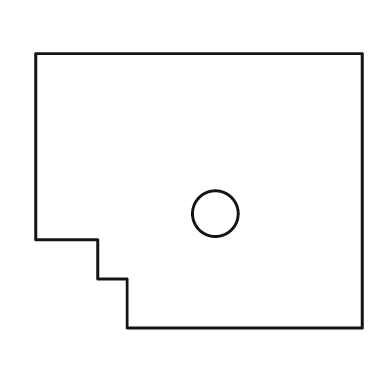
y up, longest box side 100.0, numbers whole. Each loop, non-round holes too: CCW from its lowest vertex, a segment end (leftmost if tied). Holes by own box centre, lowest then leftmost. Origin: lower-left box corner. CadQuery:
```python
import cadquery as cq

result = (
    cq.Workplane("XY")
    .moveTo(28.0, 0.0)
    .lineTo(100.0, 0.0)
    .lineTo(100.0, 84.0)
    .lineTo(0.0, 84.0)
    .lineTo(0.0, 27.0)
    .lineTo(19.0, 27.0)
    .lineTo(19.0, 15.0)
    .lineTo(28.0, 15.0)
    .close()
    .moveTo(55.0, 35.0)
    .circle(7.0)
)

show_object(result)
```